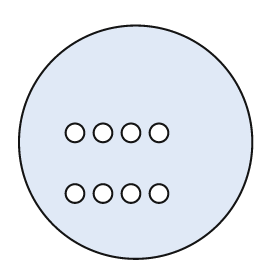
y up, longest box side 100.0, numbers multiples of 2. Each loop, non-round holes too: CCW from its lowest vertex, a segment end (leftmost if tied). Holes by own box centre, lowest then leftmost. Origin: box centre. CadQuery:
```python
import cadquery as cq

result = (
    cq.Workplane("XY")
    .moveTo(0.0, 0.0)
    .circle(50.0)
    .moveTo(-26.0, -22.0)
    .circle(4.0)
    .moveTo(-14.0, -22.0)
    .circle(4.0)
    .moveTo(-2.0, -22.0)
    .circle(4.0)
    .moveTo(10.0, -22.0)
    .circle(4.0)
    .moveTo(-26.0, 4.0)
    .circle(4.0)
    .moveTo(-14.0, 4.0)
    .circle(4.0)
    .moveTo(-2.0, 4.0)
    .circle(4.0)
    .moveTo(10.0, 4.0)
    .circle(4.0)
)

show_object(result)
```